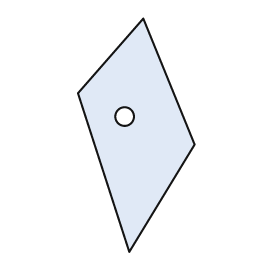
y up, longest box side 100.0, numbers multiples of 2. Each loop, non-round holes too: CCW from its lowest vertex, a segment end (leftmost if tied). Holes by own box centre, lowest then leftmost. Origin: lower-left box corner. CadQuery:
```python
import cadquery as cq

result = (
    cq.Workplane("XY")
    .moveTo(22.0, 0.0)
    .lineTo(50.0, 46.0)
    .lineTo(28.0, 100.0)
    .lineTo(0.0, 68.0)
    .close()
    .moveTo(20.0, 58.0)
    .circle(4.0)
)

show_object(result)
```